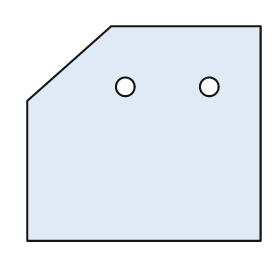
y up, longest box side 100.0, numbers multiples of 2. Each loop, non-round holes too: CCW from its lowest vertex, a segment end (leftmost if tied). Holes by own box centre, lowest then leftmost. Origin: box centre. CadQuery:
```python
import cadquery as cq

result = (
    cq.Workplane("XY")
    .moveTo(-50.0, -46.0)
    .lineTo(50.0, -46.0)
    .lineTo(50.0, 46.0)
    .lineTo(-14.0, 46.0)
    .lineTo(-50.0, 14.0)
    .close()
    .moveTo(-8.0, 20.0)
    .circle(4.0)
    .moveTo(28.0, 20.0)
    .circle(4.0)
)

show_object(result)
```